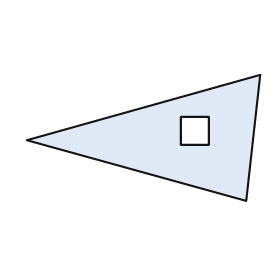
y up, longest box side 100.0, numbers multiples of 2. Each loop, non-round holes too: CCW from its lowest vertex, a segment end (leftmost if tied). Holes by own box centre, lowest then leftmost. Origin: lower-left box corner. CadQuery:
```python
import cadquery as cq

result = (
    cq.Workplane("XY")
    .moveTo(94.0, 0.0)
    .lineTo(100.0, 54.0)
    .lineTo(0.0, 26.0)
    .close()
    .moveTo(66.0, 24.0)
    .lineTo(78.0, 24.0)
    .lineTo(78.0, 36.0)
    .lineTo(66.0, 36.0)
    .close()
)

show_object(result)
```